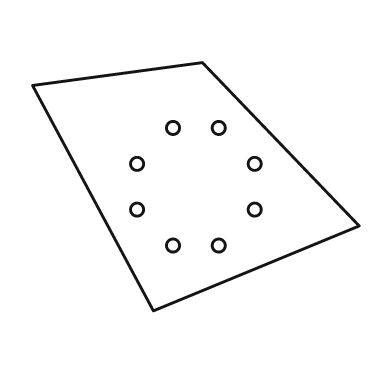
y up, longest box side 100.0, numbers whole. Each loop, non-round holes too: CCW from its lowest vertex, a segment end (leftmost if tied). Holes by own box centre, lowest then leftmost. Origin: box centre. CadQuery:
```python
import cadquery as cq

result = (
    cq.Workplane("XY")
    .moveTo(-13.0, -38.0)
    .lineTo(50.0, -12.0)
    .lineTo(2.0, 38.0)
    .lineTo(-50.0, 31.0)
    .close()
    .moveTo(-7.0, -18.0)
    .circle(2.0)
    .moveTo(7.0, -18.0)
    .circle(2.0)
    .moveTo(-18.0, -7.0)
    .circle(2.0)
    .moveTo(18.0, -7.0)
    .circle(2.0)
    .moveTo(-18.0, 7.0)
    .circle(2.0)
    .moveTo(18.0, 7.0)
    .circle(2.0)
    .moveTo(-7.0, 18.0)
    .circle(2.0)
    .moveTo(7.0, 18.0)
    .circle(2.0)
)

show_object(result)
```